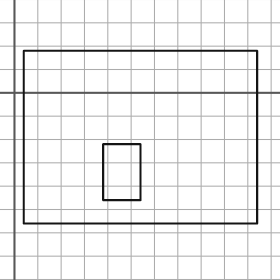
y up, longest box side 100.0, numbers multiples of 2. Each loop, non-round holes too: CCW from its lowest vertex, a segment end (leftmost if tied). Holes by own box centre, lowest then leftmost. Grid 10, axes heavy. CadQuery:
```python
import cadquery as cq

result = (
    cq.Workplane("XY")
    .moveTo(4.0, -56.0)
    .lineTo(104.0, -56.0)
    .lineTo(104.0, 18.0)
    .lineTo(4.0, 18.0)
    .close()
    .moveTo(38.0, -46.0)
    .lineTo(54.0, -46.0)
    .lineTo(54.0, -22.0)
    .lineTo(38.0, -22.0)
    .close()
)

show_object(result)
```